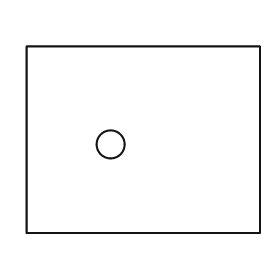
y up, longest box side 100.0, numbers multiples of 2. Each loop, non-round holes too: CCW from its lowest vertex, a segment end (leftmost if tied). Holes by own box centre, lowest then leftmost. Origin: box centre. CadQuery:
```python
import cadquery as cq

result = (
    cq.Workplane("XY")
    .moveTo(-50.0, -40.0)
    .lineTo(50.0, -40.0)
    .lineTo(50.0, 40.0)
    .lineTo(-50.0, 40.0)
    .close()
    .moveTo(-14.0, -2.0)
    .circle(6.0)
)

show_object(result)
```